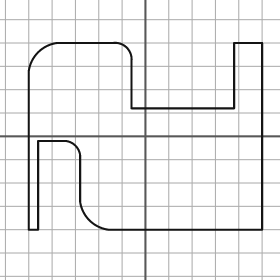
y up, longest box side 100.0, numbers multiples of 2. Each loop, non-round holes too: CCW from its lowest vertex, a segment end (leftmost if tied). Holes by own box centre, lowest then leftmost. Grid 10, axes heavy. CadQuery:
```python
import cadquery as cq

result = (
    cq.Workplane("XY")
    .moveTo(-50.0, -40.0)
    .lineTo(-46.0, -40.0)
    .lineTo(-46.0, -2.0)
    .lineTo(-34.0, -2.0)
    .threePointArc((-30.0, -4.0), (-28.0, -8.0))
    .lineTo(-28.0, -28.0)
    .threePointArc((-24.0, -36.0), (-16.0, -40.0))
    .lineTo(50.0, -40.0)
    .lineTo(50.0, 40.0)
    .lineTo(38.0, 40.0)
    .lineTo(38.0, 12.0)
    .lineTo(-6.0, 12.0)
    .lineTo(-6.0, 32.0)
    .threePointArc((-8.0, 38.0), (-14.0, 40.0))
    .lineTo(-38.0, 40.0)
    .threePointArc((-46.0, 36.0), (-50.0, 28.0))
    .close()
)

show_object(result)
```